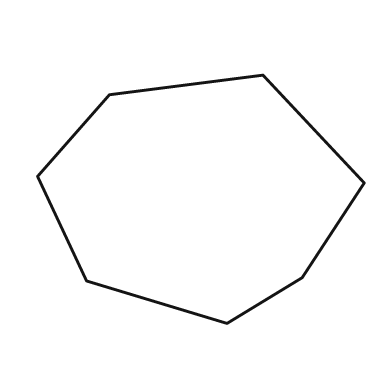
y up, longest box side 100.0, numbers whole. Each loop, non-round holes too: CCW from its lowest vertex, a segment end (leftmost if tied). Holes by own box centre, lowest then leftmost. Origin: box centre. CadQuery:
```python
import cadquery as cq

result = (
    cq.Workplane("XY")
    .moveTo(8.0, -38.0)
    .lineTo(31.0, -24.0)
    .lineTo(50.0, 5.0)
    .lineTo(19.0, 38.0)
    .lineTo(-28.0, 32.0)
    .lineTo(-50.0, 7.0)
    .lineTo(-35.0, -25.0)
    .close()
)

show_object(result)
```